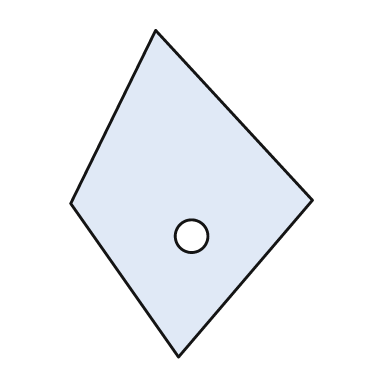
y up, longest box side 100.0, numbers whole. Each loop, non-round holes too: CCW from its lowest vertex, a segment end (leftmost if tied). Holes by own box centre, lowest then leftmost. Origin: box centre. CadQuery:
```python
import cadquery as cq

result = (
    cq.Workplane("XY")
    .moveTo(-4.0, -50.0)
    .lineTo(37.0, -2.0)
    .lineTo(-11.0, 50.0)
    .lineTo(-37.0, -3.0)
    .close()
    .moveTo(0.0, -13.0)
    .circle(5.0)
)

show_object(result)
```